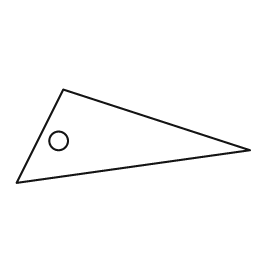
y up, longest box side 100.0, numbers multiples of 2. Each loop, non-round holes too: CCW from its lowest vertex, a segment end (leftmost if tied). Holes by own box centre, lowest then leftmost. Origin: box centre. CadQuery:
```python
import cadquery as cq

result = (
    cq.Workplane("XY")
    .moveTo(-50.0, -20.0)
    .lineTo(50.0, -6.0)
    .lineTo(-30.0, 20.0)
    .close()
    .moveTo(-32.0, -2.0)
    .circle(4.0)
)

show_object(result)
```